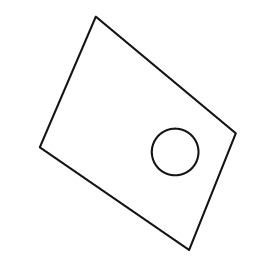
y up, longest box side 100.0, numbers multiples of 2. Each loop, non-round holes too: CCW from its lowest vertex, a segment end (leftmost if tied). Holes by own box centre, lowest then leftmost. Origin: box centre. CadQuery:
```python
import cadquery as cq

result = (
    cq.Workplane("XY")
    .moveTo(22.0, -50.0)
    .lineTo(42.0, 0.0)
    .lineTo(-18.0, 50.0)
    .lineTo(-42.0, -6.0)
    .close()
    .moveTo(16.0, -8.0)
    .circle(10.0)
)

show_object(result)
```